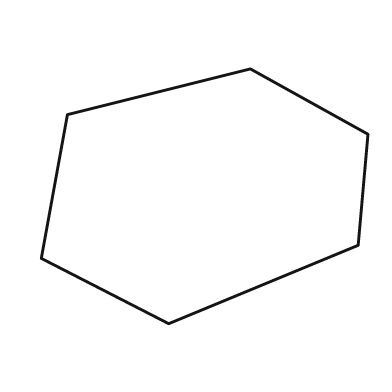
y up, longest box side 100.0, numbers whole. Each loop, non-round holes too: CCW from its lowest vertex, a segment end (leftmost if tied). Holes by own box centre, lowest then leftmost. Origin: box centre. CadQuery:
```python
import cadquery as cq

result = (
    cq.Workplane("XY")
    .moveTo(-11.0, -39.0)
    .lineTo(47.0, -15.0)
    .lineTo(50.0, 19.0)
    .lineTo(14.0, 39.0)
    .lineTo(-42.0, 25.0)
    .lineTo(-50.0, -19.0)
    .close()
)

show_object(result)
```